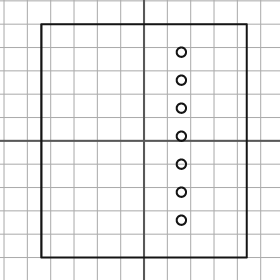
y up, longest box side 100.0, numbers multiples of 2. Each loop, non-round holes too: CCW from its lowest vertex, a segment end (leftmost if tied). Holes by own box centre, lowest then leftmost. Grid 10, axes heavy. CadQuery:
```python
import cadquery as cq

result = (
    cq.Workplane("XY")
    .moveTo(-44.0, -50.0)
    .lineTo(44.0, -50.0)
    .lineTo(44.0, 50.0)
    .lineTo(-44.0, 50.0)
    .close()
    .moveTo(16.0, -34.0)
    .circle(2.0)
    .moveTo(16.0, -22.0)
    .circle(2.0)
    .moveTo(16.0, -10.0)
    .circle(2.0)
    .moveTo(16.0, 2.0)
    .circle(2.0)
    .moveTo(16.0, 14.0)
    .circle(2.0)
    .moveTo(16.0, 26.0)
    .circle(2.0)
    .moveTo(16.0, 38.0)
    .circle(2.0)
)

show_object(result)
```